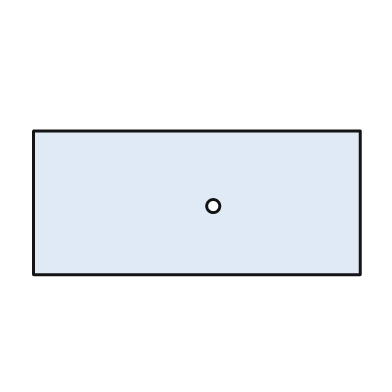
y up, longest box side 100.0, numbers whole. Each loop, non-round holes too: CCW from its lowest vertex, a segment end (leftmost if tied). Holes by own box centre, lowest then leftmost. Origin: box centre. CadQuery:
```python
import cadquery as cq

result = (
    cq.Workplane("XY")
    .moveTo(-50.0, -22.0)
    .lineTo(50.0, -22.0)
    .lineTo(50.0, 22.0)
    .lineTo(-50.0, 22.0)
    .close()
    .moveTo(5.0, -1.0)
    .circle(2.0)
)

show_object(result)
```